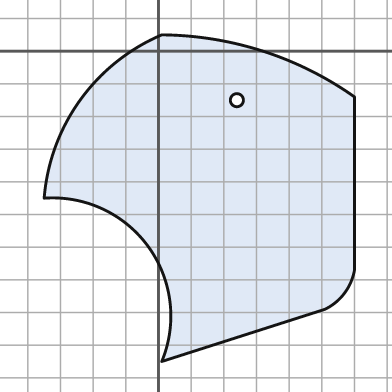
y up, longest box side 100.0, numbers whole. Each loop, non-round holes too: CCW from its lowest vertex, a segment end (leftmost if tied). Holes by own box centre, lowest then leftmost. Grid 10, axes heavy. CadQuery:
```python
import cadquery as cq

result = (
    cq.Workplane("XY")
    .moveTo(1.0, -95.0)
    .lineTo(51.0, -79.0)
    .threePointArc((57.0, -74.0), (60.0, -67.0))
    .lineTo(60.0, -14.0)
    .threePointArc((32.0, 0.0), (1.0, 5.0))
    .threePointArc((-24.0, -15.0), (-35.0, -45.0))
    .threePointArc((-3.0, -60.0), (1.0, -95.0))
    .close()
    .moveTo(24.0, -15.0)
    .circle(2.0)
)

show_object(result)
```